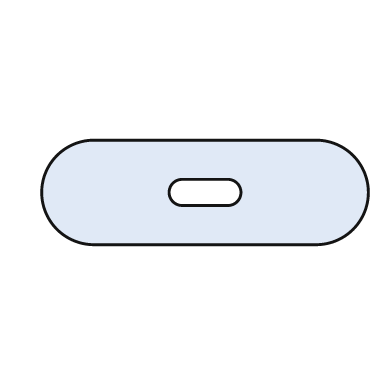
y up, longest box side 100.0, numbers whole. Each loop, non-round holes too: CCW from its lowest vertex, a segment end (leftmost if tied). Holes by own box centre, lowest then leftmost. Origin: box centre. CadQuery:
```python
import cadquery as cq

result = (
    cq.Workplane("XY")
    .moveTo(-34.0, -16.0)
    .lineTo(34.0, -16.0)
    .threePointArc((50.0, 0.0), (34.0, 16.0))
    .lineTo(-34.0, 16.0)
    .threePointArc((-50.0, 0.0), (-34.0, -16.0))
    .close()
    .moveTo(-7.0, -4.0)
    .lineTo(7.0, -4.0)
    .threePointArc((11.0, 0.0), (7.0, 4.0))
    .lineTo(-7.0, 4.0)
    .threePointArc((-11.0, 0.0), (-7.0, -4.0))
    .close()
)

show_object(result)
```